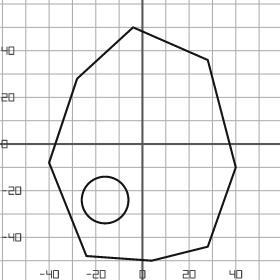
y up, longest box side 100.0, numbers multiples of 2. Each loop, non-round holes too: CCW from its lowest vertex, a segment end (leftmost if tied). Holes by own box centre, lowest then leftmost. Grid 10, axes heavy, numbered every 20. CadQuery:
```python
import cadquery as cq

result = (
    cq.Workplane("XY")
    .moveTo(4.0, -50.0)
    .lineTo(28.0, -44.0)
    .lineTo(40.0, -10.0)
    .lineTo(28.0, 36.0)
    .lineTo(-4.0, 50.0)
    .lineTo(-28.0, 28.0)
    .lineTo(-40.0, -8.0)
    .lineTo(-24.0, -48.0)
    .close()
    .moveTo(-16.0, -24.0)
    .circle(10.0)
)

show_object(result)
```